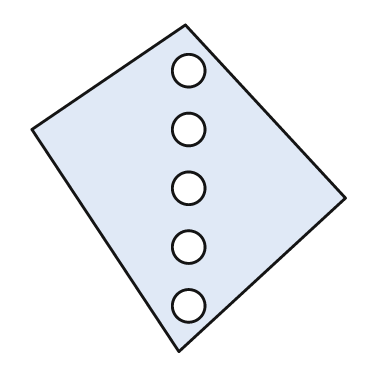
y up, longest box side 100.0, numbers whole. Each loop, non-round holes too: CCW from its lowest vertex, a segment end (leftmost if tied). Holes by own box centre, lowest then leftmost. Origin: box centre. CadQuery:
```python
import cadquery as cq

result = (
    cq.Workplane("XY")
    .moveTo(-3.0, -50.0)
    .lineTo(48.0, -3.0)
    .lineTo(-1.0, 50.0)
    .lineTo(-48.0, 18.0)
    .close()
    .moveTo(0.0, -36.0)
    .circle(5.0)
    .moveTo(0.0, -18.0)
    .circle(5.0)
    .moveTo(0.0, 0.0)
    .circle(5.0)
    .moveTo(0.0, 18.0)
    .circle(5.0)
    .moveTo(0.0, 36.0)
    .circle(5.0)
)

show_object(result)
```